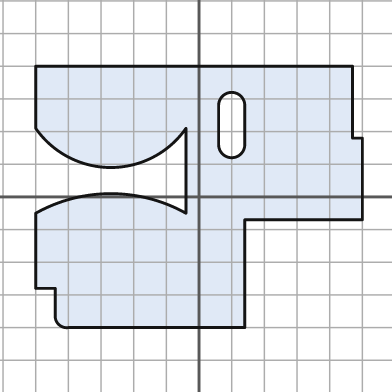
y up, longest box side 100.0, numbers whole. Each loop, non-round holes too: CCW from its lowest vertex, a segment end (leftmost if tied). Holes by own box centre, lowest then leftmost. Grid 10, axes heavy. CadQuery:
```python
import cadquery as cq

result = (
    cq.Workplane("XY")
    .moveTo(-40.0, -40.0)
    .lineTo(14.0, -40.0)
    .lineTo(14.0, -7.0)
    .lineTo(50.0, -7.0)
    .lineTo(50.0, 18.0)
    .lineTo(47.0, 18.0)
    .lineTo(47.0, 40.0)
    .lineTo(-50.0, 40.0)
    .lineTo(-50.0, 21.0)
    .threePointArc((-27.0, 9.0), (-4.0, 21.0))
    .lineTo(-4.0, -5.0)
    .threePointArc((-27.0, 1.0), (-50.0, -5.0))
    .lineTo(-50.0, -28.0)
    .lineTo(-44.0, -28.0)
    .lineTo(-44.0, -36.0)
    .threePointArc((-43.0, -39.0), (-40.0, -40.0))
    .close()
    .moveTo(6.0, 16.0)
    .threePointArc((10.0, 12.0), (14.0, 16.0))
    .lineTo(14.0, 28.0)
    .threePointArc((10.0, 32.0), (6.0, 28.0))
    .close()
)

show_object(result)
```